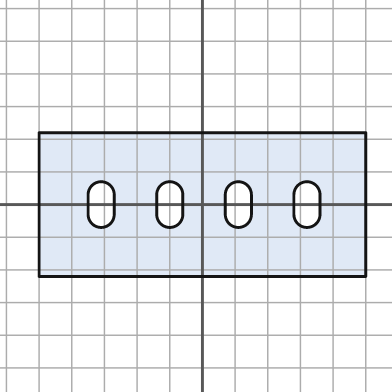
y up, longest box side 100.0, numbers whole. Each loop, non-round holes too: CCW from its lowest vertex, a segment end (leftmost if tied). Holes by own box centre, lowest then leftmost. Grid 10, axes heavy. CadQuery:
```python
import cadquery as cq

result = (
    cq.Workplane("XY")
    .moveTo(-50.0, -22.0)
    .lineTo(50.0, -22.0)
    .lineTo(50.0, 22.0)
    .lineTo(-50.0, 22.0)
    .close()
    .moveTo(-35.0, -3.0)
    .threePointArc((-31.0, -7.0), (-27.0, -3.0))
    .lineTo(-27.0, 3.0)
    .threePointArc((-31.0, 7.0), (-35.0, 3.0))
    .close()
    .moveTo(-14.0, -3.0)
    .threePointArc((-10.0, -7.0), (-6.0, -3.0))
    .lineTo(-6.0, 3.0)
    .threePointArc((-10.0, 7.0), (-14.0, 3.0))
    .close()
    .moveTo(7.0, -3.0)
    .threePointArc((11.0, -7.0), (15.0, -3.0))
    .lineTo(15.0, 3.0)
    .threePointArc((11.0, 7.0), (7.0, 3.0))
    .close()
    .moveTo(28.0, -3.0)
    .threePointArc((32.0, -7.0), (36.0, -3.0))
    .lineTo(36.0, 3.0)
    .threePointArc((32.0, 7.0), (28.0, 3.0))
    .close()
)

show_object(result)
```